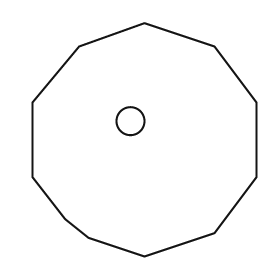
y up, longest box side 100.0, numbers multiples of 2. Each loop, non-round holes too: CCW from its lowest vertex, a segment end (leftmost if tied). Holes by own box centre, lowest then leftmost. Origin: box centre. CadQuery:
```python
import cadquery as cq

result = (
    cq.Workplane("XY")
    .moveTo(0.0, -50.0)
    .lineTo(30.0, -40.0)
    .lineTo(48.0, -16.0)
    .lineTo(48.0, 16.0)
    .lineTo(30.0, 40.0)
    .lineTo(0.0, 50.0)
    .lineTo(-28.0, 40.0)
    .lineTo(-48.0, 16.0)
    .lineTo(-48.0, -16.0)
    .lineTo(-34.0, -34.0)
    .lineTo(-24.0, -42.0)
    .close()
    .moveTo(-6.0, 8.0)
    .circle(6.0)
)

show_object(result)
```